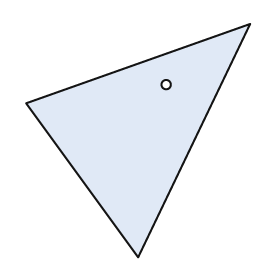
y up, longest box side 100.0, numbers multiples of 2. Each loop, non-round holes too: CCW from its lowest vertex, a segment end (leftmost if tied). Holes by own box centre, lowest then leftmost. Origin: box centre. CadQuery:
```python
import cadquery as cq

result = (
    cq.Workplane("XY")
    .moveTo(0.0, -50.0)
    .lineTo(48.0, 50.0)
    .lineTo(-48.0, 16.0)
    .close()
    .moveTo(12.0, 24.0)
    .circle(2.0)
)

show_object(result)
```